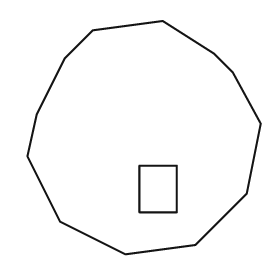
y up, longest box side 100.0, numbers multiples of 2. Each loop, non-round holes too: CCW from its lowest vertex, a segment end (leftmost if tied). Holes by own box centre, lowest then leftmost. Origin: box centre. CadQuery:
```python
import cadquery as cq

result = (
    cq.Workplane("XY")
    .moveTo(-8.0, -50.0)
    .lineTo(22.0, -46.0)
    .lineTo(44.0, -24.0)
    .lineTo(50.0, 6.0)
    .lineTo(38.0, 28.0)
    .lineTo(30.0, 36.0)
    .lineTo(8.0, 50.0)
    .lineTo(-22.0, 46.0)
    .lineTo(-34.0, 34.0)
    .lineTo(-46.0, 10.0)
    .lineTo(-50.0, -8.0)
    .lineTo(-36.0, -36.0)
    .close()
    .moveTo(-2.0, -32.0)
    .lineTo(14.0, -32.0)
    .lineTo(14.0, -12.0)
    .lineTo(-2.0, -12.0)
    .close()
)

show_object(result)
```